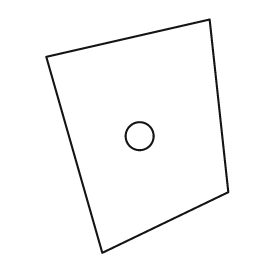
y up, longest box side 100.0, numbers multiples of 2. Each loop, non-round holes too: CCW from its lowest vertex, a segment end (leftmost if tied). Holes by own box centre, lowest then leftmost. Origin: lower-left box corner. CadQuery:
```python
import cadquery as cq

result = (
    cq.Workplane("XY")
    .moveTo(24.0, 0.0)
    .lineTo(78.0, 26.0)
    .lineTo(70.0, 100.0)
    .lineTo(0.0, 84.0)
    .close()
    .moveTo(40.0, 50.0)
    .circle(6.0)
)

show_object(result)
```